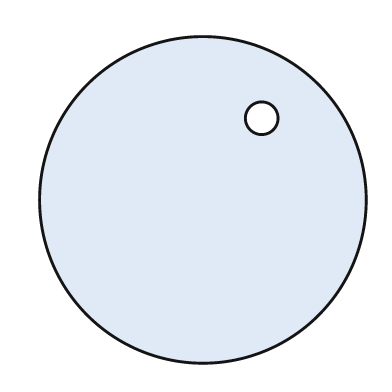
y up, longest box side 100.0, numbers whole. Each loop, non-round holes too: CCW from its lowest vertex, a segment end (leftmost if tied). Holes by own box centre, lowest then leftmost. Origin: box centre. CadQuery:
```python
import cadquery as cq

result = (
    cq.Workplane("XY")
    .moveTo(0.0, 0.0)
    .circle(50.0)
    .moveTo(18.0, 25.0)
    .circle(5.0)
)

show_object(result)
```